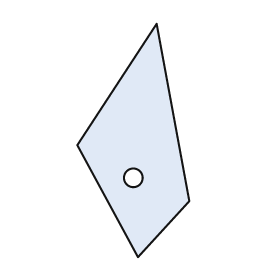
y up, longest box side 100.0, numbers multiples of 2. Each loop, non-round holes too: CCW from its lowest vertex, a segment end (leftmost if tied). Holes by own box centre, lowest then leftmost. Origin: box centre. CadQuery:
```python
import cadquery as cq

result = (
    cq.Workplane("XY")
    .moveTo(2.0, -50.0)
    .lineTo(24.0, -26.0)
    .lineTo(10.0, 50.0)
    .lineTo(-24.0, -2.0)
    .close()
    .moveTo(0.0, -16.0)
    .circle(4.0)
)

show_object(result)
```